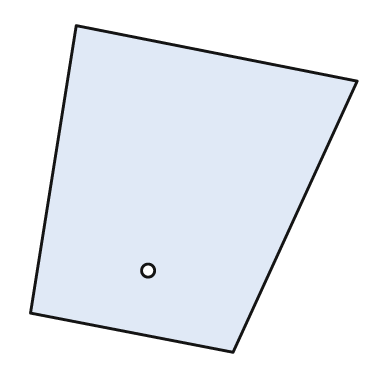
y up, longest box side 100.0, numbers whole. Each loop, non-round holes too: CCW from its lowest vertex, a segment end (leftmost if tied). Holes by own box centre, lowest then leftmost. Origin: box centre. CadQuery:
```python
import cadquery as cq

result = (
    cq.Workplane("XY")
    .moveTo(12.0, -50.0)
    .lineTo(50.0, 33.0)
    .lineTo(-36.0, 50.0)
    .lineTo(-50.0, -38.0)
    .close()
    .moveTo(-14.0, -25.0)
    .circle(2.0)
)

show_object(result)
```